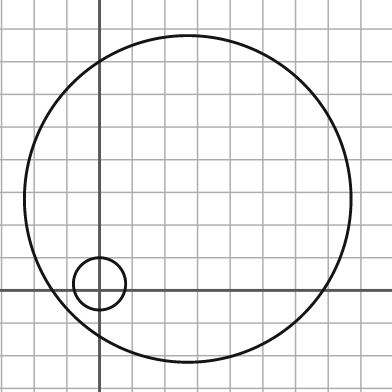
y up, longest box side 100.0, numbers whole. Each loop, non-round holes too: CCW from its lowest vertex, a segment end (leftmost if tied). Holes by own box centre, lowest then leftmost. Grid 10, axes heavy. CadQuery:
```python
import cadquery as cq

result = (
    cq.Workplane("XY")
    .moveTo(27.0, 28.0)
    .circle(50.0)
    .moveTo(0.0, 2.0)
    .circle(8.0)
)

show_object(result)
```